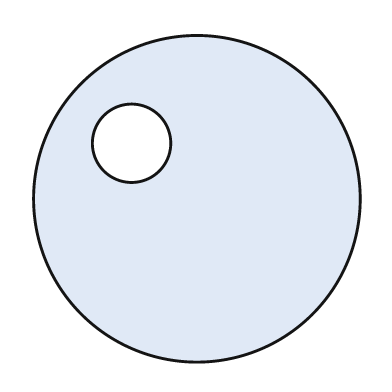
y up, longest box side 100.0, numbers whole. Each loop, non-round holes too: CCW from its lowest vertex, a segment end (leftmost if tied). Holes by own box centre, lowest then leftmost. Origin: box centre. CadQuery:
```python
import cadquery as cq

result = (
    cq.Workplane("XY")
    .moveTo(0.0, 0.0)
    .circle(50.0)
    .moveTo(-20.0, 17.0)
    .circle(12.0)
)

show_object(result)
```